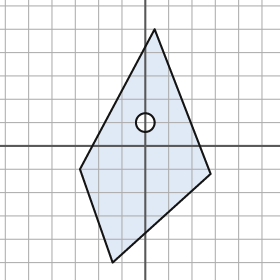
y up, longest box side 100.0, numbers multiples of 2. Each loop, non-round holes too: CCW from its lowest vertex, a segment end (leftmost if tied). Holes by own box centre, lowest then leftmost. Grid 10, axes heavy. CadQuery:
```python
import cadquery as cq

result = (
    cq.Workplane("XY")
    .moveTo(-14.0, -50.0)
    .lineTo(28.0, -12.0)
    .lineTo(4.0, 50.0)
    .lineTo(-28.0, -10.0)
    .close()
    .moveTo(0.0, 10.0)
    .circle(4.0)
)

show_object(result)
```